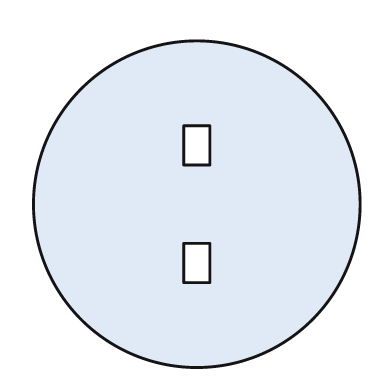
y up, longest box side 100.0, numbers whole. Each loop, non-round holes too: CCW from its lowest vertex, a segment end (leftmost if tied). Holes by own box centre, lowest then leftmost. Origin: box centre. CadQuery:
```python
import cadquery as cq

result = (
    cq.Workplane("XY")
    .moveTo(0.0, 0.0)
    .circle(50.0)
    .moveTo(-4.0, -24.0)
    .lineTo(4.0, -24.0)
    .lineTo(4.0, -12.0)
    .lineTo(-4.0, -12.0)
    .close()
    .moveTo(-4.0, 12.0)
    .lineTo(4.0, 12.0)
    .lineTo(4.0, 24.0)
    .lineTo(-4.0, 24.0)
    .close()
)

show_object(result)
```